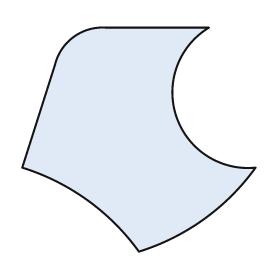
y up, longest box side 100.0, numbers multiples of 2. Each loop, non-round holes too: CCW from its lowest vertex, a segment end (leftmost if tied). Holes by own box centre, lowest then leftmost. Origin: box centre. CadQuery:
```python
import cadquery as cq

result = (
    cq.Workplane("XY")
    .moveTo(0.0, -48.0)
    .threePointArc((28.0, -34.0), (50.0, -12.0))
    .threePointArc((16.0, 10.0), (30.0, 48.0))
    .lineTo(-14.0, 48.0)
    .threePointArc((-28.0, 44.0), (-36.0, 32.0))
    .lineTo(-50.0, -12.0)
    .threePointArc((-22.0, -26.0), (0.0, -48.0))
    .close()
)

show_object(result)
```